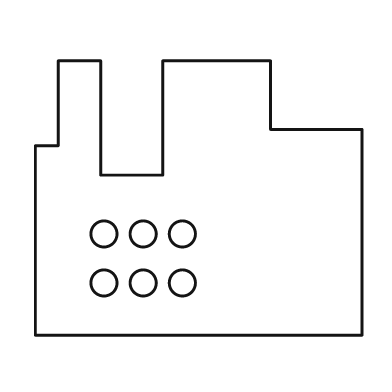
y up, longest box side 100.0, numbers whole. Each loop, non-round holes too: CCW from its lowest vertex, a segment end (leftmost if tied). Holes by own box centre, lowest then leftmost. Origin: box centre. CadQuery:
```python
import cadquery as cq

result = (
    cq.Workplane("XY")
    .moveTo(-50.0, -42.0)
    .lineTo(50.0, -42.0)
    .lineTo(50.0, 21.0)
    .lineTo(22.0, 21.0)
    .lineTo(22.0, 42.0)
    .lineTo(-11.0, 42.0)
    .lineTo(-11.0, 7.0)
    .lineTo(-30.0, 7.0)
    .lineTo(-30.0, 42.0)
    .lineTo(-43.0, 42.0)
    .lineTo(-43.0, 16.0)
    .lineTo(-50.0, 16.0)
    .close()
    .moveTo(-29.0, -26.0)
    .circle(4.0)
    .moveTo(-17.0, -26.0)
    .circle(4.0)
    .moveTo(-5.0, -26.0)
    .circle(4.0)
    .moveTo(-29.0, -11.0)
    .circle(4.0)
    .moveTo(-17.0, -11.0)
    .circle(4.0)
    .moveTo(-5.0, -11.0)
    .circle(4.0)
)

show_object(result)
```